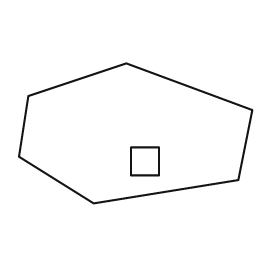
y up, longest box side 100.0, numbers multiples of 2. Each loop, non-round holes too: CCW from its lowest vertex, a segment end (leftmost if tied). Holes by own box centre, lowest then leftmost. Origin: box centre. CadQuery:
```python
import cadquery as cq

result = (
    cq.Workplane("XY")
    .moveTo(-18.0, -30.0)
    .lineTo(44.0, -20.0)
    .lineTo(50.0, 10.0)
    .lineTo(-4.0, 30.0)
    .lineTo(-46.0, 16.0)
    .lineTo(-50.0, -10.0)
    .close()
    .moveTo(-2.0, -18.0)
    .lineTo(10.0, -18.0)
    .lineTo(10.0, -6.0)
    .lineTo(-2.0, -6.0)
    .close()
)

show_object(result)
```